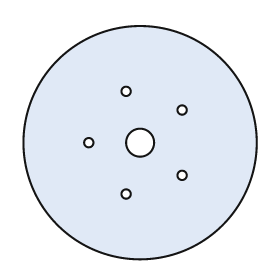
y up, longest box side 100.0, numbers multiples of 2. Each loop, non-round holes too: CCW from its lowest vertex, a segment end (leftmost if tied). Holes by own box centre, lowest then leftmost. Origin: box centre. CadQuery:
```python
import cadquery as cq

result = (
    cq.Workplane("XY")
    .moveTo(0.0, 0.0)
    .circle(50.0)
    .moveTo(-6.0, -22.0)
    .circle(2.0)
    .moveTo(18.0, -14.0)
    .circle(2.0)
    .moveTo(-22.0, 0.0)
    .circle(2.0)
    .moveTo(0.0, 0.0)
    .circle(6.0)
    .moveTo(18.0, 14.0)
    .circle(2.0)
    .moveTo(-6.0, 22.0)
    .circle(2.0)
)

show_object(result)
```